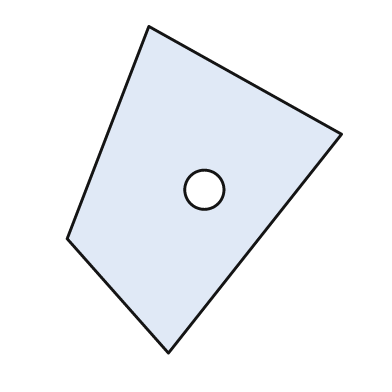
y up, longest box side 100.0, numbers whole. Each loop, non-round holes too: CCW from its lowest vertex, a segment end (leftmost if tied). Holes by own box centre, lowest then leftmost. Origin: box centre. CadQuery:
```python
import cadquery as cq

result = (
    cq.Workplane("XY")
    .moveTo(-11.0, -50.0)
    .lineTo(42.0, 17.0)
    .lineTo(-17.0, 50.0)
    .lineTo(-42.0, -15.0)
    .close()
    .moveTo(0.0, 0.0)
    .circle(6.0)
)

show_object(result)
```